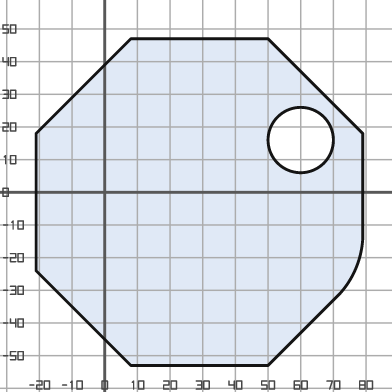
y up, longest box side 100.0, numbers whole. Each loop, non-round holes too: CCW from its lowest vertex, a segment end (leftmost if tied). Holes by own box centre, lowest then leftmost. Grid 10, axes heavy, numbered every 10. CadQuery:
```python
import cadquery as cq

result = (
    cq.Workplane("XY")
    .moveTo(8.0, -53.0)
    .lineTo(50.0, -53.0)
    .lineTo(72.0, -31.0)
    .threePointArc((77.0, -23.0), (79.0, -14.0))
    .lineTo(79.0, 18.0)
    .lineTo(50.0, 47.0)
    .lineTo(8.0, 47.0)
    .lineTo(-21.0, 18.0)
    .lineTo(-21.0, -24.0)
    .close()
    .moveTo(60.0, 16.0)
    .circle(10.0)
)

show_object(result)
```